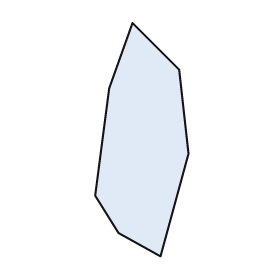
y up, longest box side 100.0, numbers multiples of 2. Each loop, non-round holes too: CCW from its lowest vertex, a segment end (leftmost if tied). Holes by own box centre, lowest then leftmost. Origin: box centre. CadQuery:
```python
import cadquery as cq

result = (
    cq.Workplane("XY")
    .moveTo(8.0, -50.0)
    .lineTo(20.0, -6.0)
    .lineTo(16.0, 30.0)
    .lineTo(-4.0, 50.0)
    .lineTo(-14.0, 22.0)
    .lineTo(-20.0, -24.0)
    .lineTo(-10.0, -40.0)
    .close()
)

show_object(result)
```